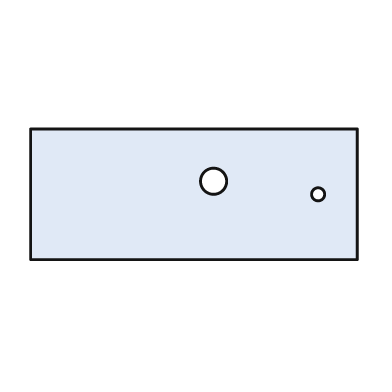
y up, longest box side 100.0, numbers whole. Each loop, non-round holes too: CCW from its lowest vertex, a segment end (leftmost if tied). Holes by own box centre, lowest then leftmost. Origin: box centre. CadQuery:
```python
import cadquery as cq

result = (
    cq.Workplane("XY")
    .moveTo(-50.0, -20.0)
    .lineTo(50.0, -20.0)
    .lineTo(50.0, 20.0)
    .lineTo(-50.0, 20.0)
    .close()
    .moveTo(38.0, 0.0)
    .circle(2.0)
    .moveTo(6.0, 4.0)
    .circle(4.0)
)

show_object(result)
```